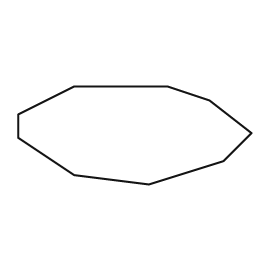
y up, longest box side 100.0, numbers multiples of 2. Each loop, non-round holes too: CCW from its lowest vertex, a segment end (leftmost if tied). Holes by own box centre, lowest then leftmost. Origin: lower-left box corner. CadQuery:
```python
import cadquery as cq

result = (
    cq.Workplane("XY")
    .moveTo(56.0, 0.0)
    .lineTo(88.0, 10.0)
    .lineTo(100.0, 22.0)
    .lineTo(82.0, 36.0)
    .lineTo(64.0, 42.0)
    .lineTo(24.0, 42.0)
    .lineTo(0.0, 30.0)
    .lineTo(0.0, 20.0)
    .lineTo(24.0, 4.0)
    .close()
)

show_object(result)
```